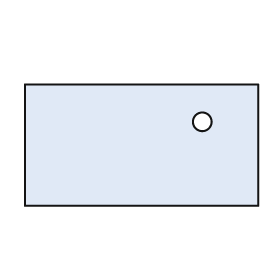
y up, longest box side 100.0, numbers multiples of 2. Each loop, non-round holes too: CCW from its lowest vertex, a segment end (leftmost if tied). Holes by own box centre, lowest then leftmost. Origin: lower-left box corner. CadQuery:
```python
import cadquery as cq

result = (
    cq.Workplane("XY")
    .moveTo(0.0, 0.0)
    .lineTo(100.0, 0.0)
    .lineTo(100.0, 52.0)
    .lineTo(0.0, 52.0)
    .close()
    .moveTo(76.0, 36.0)
    .circle(4.0)
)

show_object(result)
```